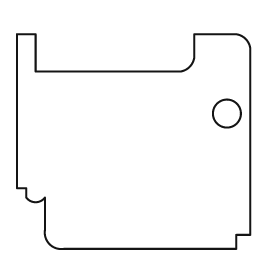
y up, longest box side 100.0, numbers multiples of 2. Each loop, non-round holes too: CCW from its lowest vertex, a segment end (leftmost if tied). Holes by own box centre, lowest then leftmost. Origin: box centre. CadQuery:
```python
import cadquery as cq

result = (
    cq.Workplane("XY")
    .moveTo(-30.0, -46.0)
    .lineTo(44.0, -46.0)
    .lineTo(44.0, -40.0)
    .lineTo(50.0, -40.0)
    .lineTo(50.0, 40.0)
    .threePointArc((48.0, 44.0), (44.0, 46.0))
    .lineTo(26.0, 46.0)
    .lineTo(26.0, 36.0)
    .threePointArc((24.0, 32.0), (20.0, 30.0))
    .lineTo(-42.0, 30.0)
    .lineTo(-42.0, 46.0)
    .lineTo(-50.0, 46.0)
    .lineTo(-50.0, -20.0)
    .lineTo(-46.0, -20.0)
    .lineTo(-46.0, -24.0)
    .threePointArc((-42.0, -26.0), (-38.0, -24.0))
    .lineTo(-38.0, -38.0)
    .threePointArc((-36.0, -44.0), (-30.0, -46.0))
    .close()
    .moveTo(40.0, 12.0)
    .circle(6.0)
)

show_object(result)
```